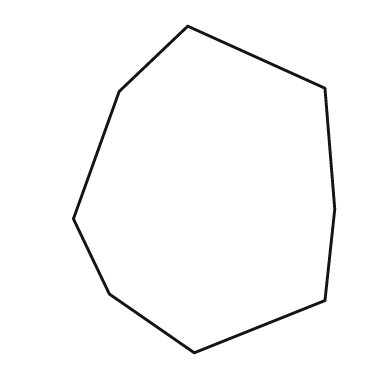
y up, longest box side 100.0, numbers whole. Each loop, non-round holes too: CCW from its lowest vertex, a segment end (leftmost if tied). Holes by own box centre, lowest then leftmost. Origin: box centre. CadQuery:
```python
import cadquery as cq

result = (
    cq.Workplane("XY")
    .moveTo(-3.0, -50.0)
    .lineTo(37.0, -34.0)
    .lineTo(40.0, -6.0)
    .lineTo(37.0, 31.0)
    .lineTo(-5.0, 50.0)
    .lineTo(-26.0, 30.0)
    .lineTo(-40.0, -9.0)
    .lineTo(-29.0, -32.0)
    .close()
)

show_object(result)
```